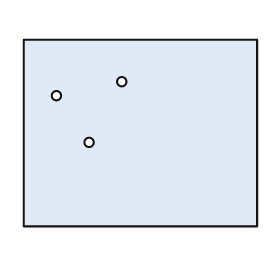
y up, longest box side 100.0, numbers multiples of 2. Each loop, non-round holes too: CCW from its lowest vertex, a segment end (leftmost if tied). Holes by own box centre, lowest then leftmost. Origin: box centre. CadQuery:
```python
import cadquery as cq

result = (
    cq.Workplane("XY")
    .moveTo(-50.0, -40.0)
    .lineTo(50.0, -40.0)
    .lineTo(50.0, 40.0)
    .lineTo(-50.0, 40.0)
    .close()
    .moveTo(-22.0, -4.0)
    .circle(2.0)
    .moveTo(-36.0, 16.0)
    .circle(2.0)
    .moveTo(-8.0, 22.0)
    .circle(2.0)
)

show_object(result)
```